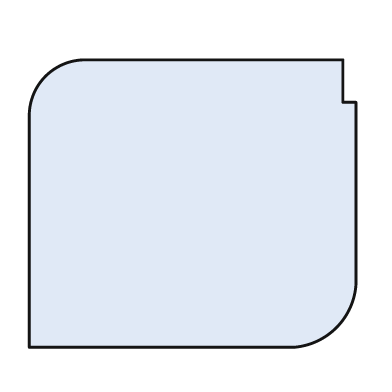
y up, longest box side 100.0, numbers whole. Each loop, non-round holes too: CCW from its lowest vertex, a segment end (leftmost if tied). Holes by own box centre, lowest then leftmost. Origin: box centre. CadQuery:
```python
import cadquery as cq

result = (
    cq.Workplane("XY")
    .moveTo(-50.0, -44.0)
    .lineTo(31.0, -44.0)
    .threePointArc((44.0, -38.0), (50.0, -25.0))
    .lineTo(50.0, 31.0)
    .lineTo(46.0, 31.0)
    .lineTo(46.0, 44.0)
    .lineTo(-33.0, 44.0)
    .threePointArc((-45.0, 39.0), (-50.0, 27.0))
    .close()
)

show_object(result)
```